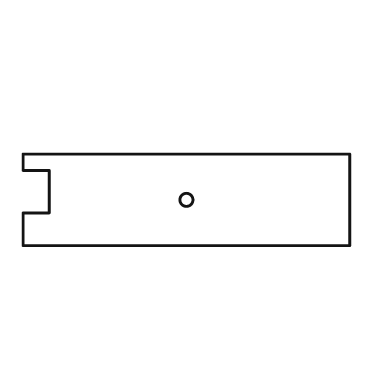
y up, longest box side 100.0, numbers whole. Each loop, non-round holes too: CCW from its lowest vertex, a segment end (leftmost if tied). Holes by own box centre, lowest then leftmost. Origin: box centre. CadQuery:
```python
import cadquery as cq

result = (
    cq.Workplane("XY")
    .moveTo(-50.0, -14.0)
    .lineTo(50.0, -14.0)
    .lineTo(50.0, 14.0)
    .lineTo(-50.0, 14.0)
    .lineTo(-50.0, 9.0)
    .lineTo(-42.0, 9.0)
    .lineTo(-42.0, -4.0)
    .lineTo(-50.0, -4.0)
    .close()
    .moveTo(0.0, 0.0)
    .circle(2.0)
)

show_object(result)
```